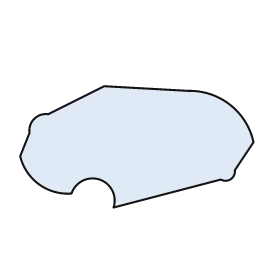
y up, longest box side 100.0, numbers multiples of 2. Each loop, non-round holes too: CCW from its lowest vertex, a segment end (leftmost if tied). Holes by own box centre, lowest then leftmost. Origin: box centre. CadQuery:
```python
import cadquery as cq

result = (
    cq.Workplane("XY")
    .moveTo(-10.0, -26.0)
    .lineTo(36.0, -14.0)
    .threePointArc((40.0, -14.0), (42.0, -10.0))
    .lineTo(50.0, 2.0)
    .threePointArc((40.0, 18.0), (22.0, 24.0))
    .lineTo(-14.0, 26.0)
    .lineTo(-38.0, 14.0)
    .threePointArc((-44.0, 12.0), (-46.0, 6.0))
    .lineTo(-50.0, -4.0)
    .threePointArc((-42.0, -16.0), (-28.0, -20.0))
    .threePointArc((-16.0, -14.0), (-10.0, -26.0))
    .close()
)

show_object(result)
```